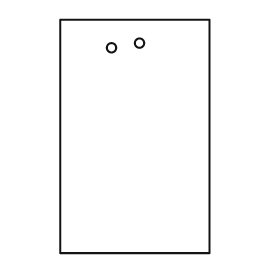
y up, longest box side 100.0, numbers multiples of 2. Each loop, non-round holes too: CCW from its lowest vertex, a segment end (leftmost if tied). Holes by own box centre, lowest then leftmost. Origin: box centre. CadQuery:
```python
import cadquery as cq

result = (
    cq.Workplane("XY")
    .moveTo(-32.0, -50.0)
    .lineTo(32.0, -50.0)
    .lineTo(32.0, 50.0)
    .lineTo(-32.0, 50.0)
    .close()
    .moveTo(-10.0, 38.0)
    .circle(2.0)
    .moveTo(2.0, 40.0)
    .circle(2.0)
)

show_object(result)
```